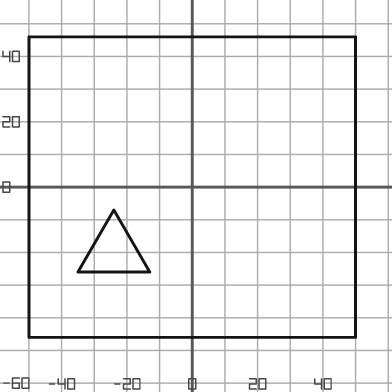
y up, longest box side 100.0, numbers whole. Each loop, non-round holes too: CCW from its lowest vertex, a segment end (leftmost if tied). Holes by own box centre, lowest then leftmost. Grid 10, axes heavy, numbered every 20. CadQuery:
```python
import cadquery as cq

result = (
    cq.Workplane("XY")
    .moveTo(-50.0, -46.0)
    .lineTo(50.0, -46.0)
    .lineTo(50.0, 46.0)
    .lineTo(-50.0, 46.0)
    .close()
    .moveTo(-35.0, -26.0)
    .lineTo(-13.0, -26.0)
    .lineTo(-24.0, -7.0)
    .close()
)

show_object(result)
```